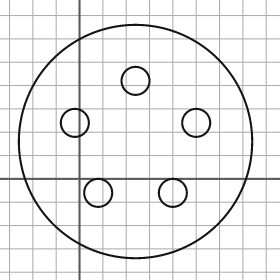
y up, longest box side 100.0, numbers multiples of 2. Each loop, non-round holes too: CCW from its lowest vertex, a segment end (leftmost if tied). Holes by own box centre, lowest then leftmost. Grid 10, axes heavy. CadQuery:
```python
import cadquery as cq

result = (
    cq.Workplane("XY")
    .moveTo(24.0, 16.0)
    .circle(50.0)
    .moveTo(8.0, -6.0)
    .circle(6.0)
    .moveTo(40.0, -6.0)
    .circle(6.0)
    .moveTo(-2.0, 24.0)
    .circle(6.0)
    .moveTo(50.0, 24.0)
    .circle(6.0)
    .moveTo(24.0, 42.0)
    .circle(6.0)
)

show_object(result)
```